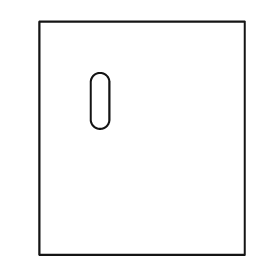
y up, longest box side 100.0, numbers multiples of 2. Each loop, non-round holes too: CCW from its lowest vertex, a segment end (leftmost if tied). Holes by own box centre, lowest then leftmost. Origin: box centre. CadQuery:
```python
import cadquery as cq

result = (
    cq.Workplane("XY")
    .moveTo(-44.0, -50.0)
    .lineTo(44.0, -50.0)
    .lineTo(44.0, 50.0)
    .lineTo(-44.0, 50.0)
    .close()
    .moveTo(-22.0, 8.0)
    .threePointArc((-18.0, 4.0), (-14.0, 8.0))
    .lineTo(-14.0, 24.0)
    .threePointArc((-18.0, 28.0), (-22.0, 24.0))
    .close()
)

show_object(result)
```